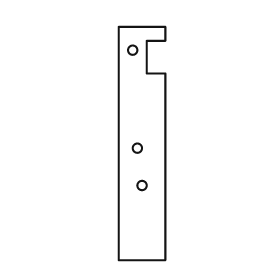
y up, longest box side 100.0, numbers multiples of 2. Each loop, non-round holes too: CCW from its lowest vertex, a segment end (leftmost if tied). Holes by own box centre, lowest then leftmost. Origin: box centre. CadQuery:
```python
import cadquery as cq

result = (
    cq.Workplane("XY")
    .moveTo(-10.0, -50.0)
    .lineTo(10.0, -50.0)
    .lineTo(10.0, 30.0)
    .lineTo(2.0, 30.0)
    .lineTo(2.0, 44.0)
    .lineTo(10.0, 44.0)
    .lineTo(10.0, 50.0)
    .lineTo(-10.0, 50.0)
    .close()
    .moveTo(0.0, -18.0)
    .circle(2.0)
    .moveTo(-2.0, -2.0)
    .circle(2.0)
    .moveTo(-4.0, 40.0)
    .circle(2.0)
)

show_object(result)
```